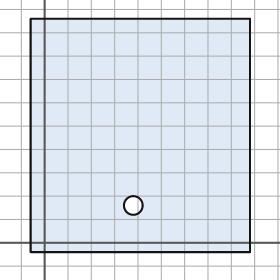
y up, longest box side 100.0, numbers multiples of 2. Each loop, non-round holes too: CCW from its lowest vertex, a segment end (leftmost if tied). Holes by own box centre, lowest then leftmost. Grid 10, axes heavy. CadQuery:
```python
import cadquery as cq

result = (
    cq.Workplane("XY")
    .moveTo(-6.0, -4.0)
    .lineTo(88.0, -4.0)
    .lineTo(88.0, 96.0)
    .lineTo(-6.0, 96.0)
    .close()
    .moveTo(38.0, 16.0)
    .circle(4.0)
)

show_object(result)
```